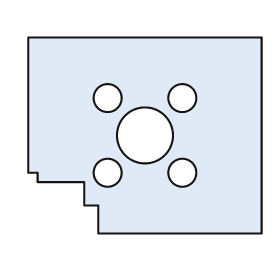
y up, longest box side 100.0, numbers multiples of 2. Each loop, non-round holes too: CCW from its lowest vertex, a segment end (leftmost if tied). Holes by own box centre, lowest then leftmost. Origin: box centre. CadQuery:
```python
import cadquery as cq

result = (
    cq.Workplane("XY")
    .moveTo(-20.0, -42.0)
    .lineTo(50.0, -42.0)
    .lineTo(50.0, 42.0)
    .lineTo(-50.0, 42.0)
    .lineTo(-50.0, -16.0)
    .lineTo(-46.0, -16.0)
    .lineTo(-46.0, -20.0)
    .lineTo(-26.0, -20.0)
    .lineTo(-26.0, -30.0)
    .lineTo(-20.0, -30.0)
    .close()
    .moveTo(-16.0, -16.0)
    .circle(6.0)
    .moveTo(16.0, -16.0)
    .circle(6.0)
    .moveTo(0.0, 0.0)
    .circle(12.0)
    .moveTo(-16.0, 16.0)
    .circle(6.0)
    .moveTo(16.0, 16.0)
    .circle(6.0)
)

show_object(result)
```